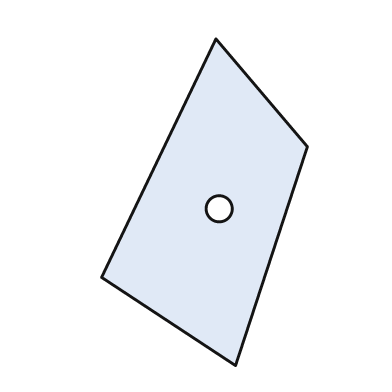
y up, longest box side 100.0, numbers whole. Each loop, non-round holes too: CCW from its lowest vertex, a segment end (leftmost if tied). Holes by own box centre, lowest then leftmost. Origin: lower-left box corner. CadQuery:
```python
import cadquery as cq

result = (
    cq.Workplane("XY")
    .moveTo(41.0, 0.0)
    .lineTo(63.0, 67.0)
    .lineTo(35.0, 100.0)
    .lineTo(0.0, 27.0)
    .close()
    .moveTo(36.0, 48.0)
    .circle(4.0)
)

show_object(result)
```